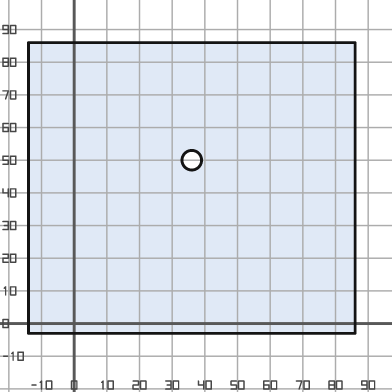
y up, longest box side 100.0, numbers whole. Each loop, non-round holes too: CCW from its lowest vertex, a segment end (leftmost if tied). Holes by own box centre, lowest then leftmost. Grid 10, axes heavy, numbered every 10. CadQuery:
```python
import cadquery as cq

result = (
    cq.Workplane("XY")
    .moveTo(-14.0, -3.0)
    .lineTo(86.0, -3.0)
    .lineTo(86.0, 86.0)
    .lineTo(-14.0, 86.0)
    .close()
    .moveTo(36.0, 50.0)
    .circle(3.0)
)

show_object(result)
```